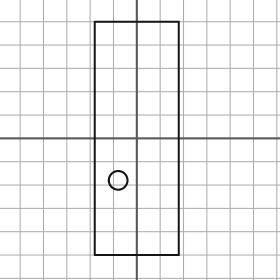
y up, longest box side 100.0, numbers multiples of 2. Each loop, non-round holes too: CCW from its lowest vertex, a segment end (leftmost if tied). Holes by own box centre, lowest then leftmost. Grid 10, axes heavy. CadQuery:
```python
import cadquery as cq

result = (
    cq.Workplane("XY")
    .moveTo(-18.0, -50.0)
    .lineTo(18.0, -50.0)
    .lineTo(18.0, 50.0)
    .lineTo(-18.0, 50.0)
    .close()
    .moveTo(-8.0, -18.0)
    .circle(4.0)
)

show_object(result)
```